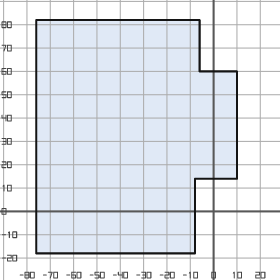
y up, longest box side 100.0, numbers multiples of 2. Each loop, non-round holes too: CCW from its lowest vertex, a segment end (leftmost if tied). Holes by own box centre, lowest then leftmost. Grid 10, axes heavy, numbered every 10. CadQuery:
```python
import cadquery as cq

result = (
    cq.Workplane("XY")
    .moveTo(-76.0, -18.0)
    .lineTo(-8.0, -18.0)
    .lineTo(-8.0, 14.0)
    .lineTo(10.0, 14.0)
    .lineTo(10.0, 60.0)
    .lineTo(-6.0, 60.0)
    .lineTo(-6.0, 82.0)
    .lineTo(-76.0, 82.0)
    .close()
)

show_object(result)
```